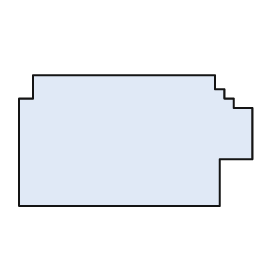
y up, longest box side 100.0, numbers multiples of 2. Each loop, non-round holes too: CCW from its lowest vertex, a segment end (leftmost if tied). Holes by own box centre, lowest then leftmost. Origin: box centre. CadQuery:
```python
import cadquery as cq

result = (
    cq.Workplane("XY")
    .moveTo(-50.0, -28.0)
    .lineTo(36.0, -28.0)
    .lineTo(36.0, -8.0)
    .lineTo(50.0, -8.0)
    .lineTo(50.0, 14.0)
    .lineTo(42.0, 14.0)
    .lineTo(42.0, 18.0)
    .lineTo(38.0, 18.0)
    .lineTo(38.0, 22.0)
    .lineTo(34.0, 22.0)
    .lineTo(34.0, 28.0)
    .lineTo(-44.0, 28.0)
    .lineTo(-44.0, 18.0)
    .lineTo(-50.0, 18.0)
    .close()
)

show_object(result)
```